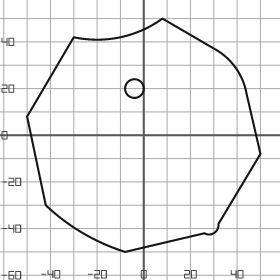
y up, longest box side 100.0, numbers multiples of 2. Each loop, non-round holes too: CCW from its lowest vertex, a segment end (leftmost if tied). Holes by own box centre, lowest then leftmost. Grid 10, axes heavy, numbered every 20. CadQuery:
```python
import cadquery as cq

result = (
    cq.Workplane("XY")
    .moveTo(-8.0, -50.0)
    .lineTo(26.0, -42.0)
    .threePointArc((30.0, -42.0), (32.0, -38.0))
    .lineTo(50.0, -8.0)
    .lineTo(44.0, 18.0)
    .threePointArc((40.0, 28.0), (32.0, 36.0))
    .lineTo(8.0, 50.0)
    .threePointArc((-10.0, 42.0), (-30.0, 42.0))
    .lineTo(-50.0, 8.0)
    .lineTo(-42.0, -30.0)
    .threePointArc((-26.0, -42.0), (-8.0, -50.0))
    .close()
    .moveTo(-4.0, 20.0)
    .circle(4.0)
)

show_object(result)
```